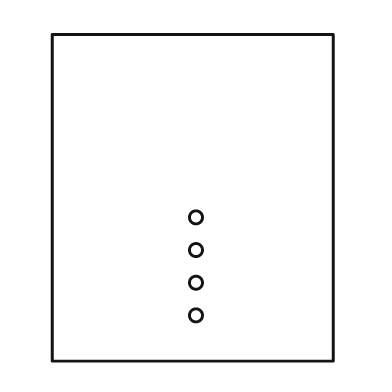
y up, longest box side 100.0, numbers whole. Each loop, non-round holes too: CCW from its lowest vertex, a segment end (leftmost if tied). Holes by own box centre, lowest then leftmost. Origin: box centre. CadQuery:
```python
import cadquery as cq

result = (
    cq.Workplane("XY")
    .moveTo(-43.0, -50.0)
    .lineTo(43.0, -50.0)
    .lineTo(43.0, 50.0)
    .lineTo(-43.0, 50.0)
    .close()
    .moveTo(1.0, -36.0)
    .circle(2.0)
    .moveTo(1.0, -26.0)
    .circle(2.0)
    .moveTo(1.0, -16.0)
    .circle(2.0)
    .moveTo(1.0, -6.0)
    .circle(2.0)
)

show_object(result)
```